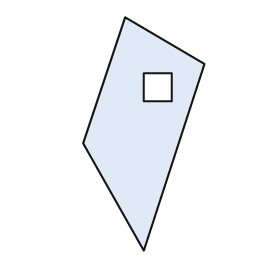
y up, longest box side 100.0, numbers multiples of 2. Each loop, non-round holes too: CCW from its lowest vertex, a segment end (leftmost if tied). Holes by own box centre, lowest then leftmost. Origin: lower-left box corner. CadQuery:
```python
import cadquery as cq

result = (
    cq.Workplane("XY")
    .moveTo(26.0, 0.0)
    .lineTo(52.0, 80.0)
    .lineTo(18.0, 100.0)
    .lineTo(0.0, 46.0)
    .close()
    .moveTo(26.0, 64.0)
    .lineTo(38.0, 64.0)
    .lineTo(38.0, 76.0)
    .lineTo(26.0, 76.0)
    .close()
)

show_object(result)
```